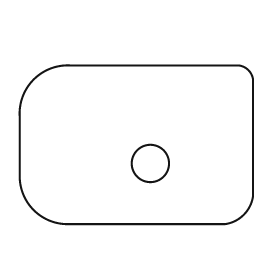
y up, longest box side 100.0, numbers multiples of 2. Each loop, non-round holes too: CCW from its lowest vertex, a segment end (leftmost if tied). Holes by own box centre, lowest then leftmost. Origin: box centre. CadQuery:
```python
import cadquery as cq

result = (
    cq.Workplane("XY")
    .moveTo(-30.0, -34.0)
    .lineTo(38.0, -34.0)
    .threePointArc((46.0, -30.0), (50.0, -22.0))
    .lineTo(50.0, 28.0)
    .threePointArc((48.0, 32.0), (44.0, 34.0))
    .lineTo(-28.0, 34.0)
    .threePointArc((-44.0, 28.0), (-50.0, 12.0))
    .lineTo(-50.0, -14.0)
    .threePointArc((-44.0, -28.0), (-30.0, -34.0))
    .close()
    .moveTo(6.0, -8.0)
    .circle(8.0)
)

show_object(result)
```